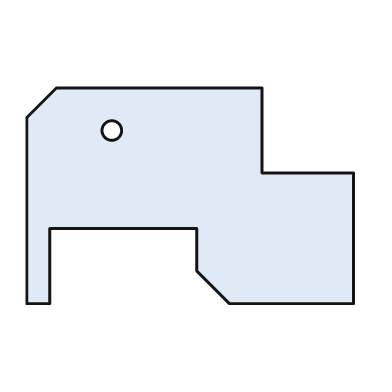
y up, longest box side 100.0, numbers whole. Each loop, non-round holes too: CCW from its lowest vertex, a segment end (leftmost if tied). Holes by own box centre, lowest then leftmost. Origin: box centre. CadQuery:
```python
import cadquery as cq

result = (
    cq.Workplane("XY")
    .moveTo(-50.0, -33.0)
    .lineTo(-43.0, -33.0)
    .lineTo(-43.0, -10.0)
    .lineTo(2.0, -10.0)
    .lineTo(2.0, -23.0)
    .lineTo(12.0, -33.0)
    .lineTo(50.0, -33.0)
    .lineTo(50.0, 7.0)
    .lineTo(22.0, 7.0)
    .lineTo(22.0, 33.0)
    .lineTo(-41.0, 33.0)
    .lineTo(-50.0, 24.0)
    .close()
    .moveTo(-24.0, 20.0)
    .circle(3.0)
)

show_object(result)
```